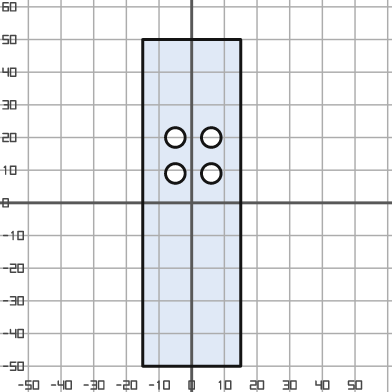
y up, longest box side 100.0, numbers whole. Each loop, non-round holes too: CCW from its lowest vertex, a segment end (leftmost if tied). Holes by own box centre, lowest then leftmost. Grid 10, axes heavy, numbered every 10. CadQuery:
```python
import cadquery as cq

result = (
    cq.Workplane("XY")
    .moveTo(-15.0, -50.0)
    .lineTo(15.0, -50.0)
    .lineTo(15.0, 50.0)
    .lineTo(-15.0, 50.0)
    .close()
    .moveTo(-5.0, 9.0)
    .circle(3.0)
    .moveTo(6.0, 9.0)
    .circle(3.0)
    .moveTo(-5.0, 20.0)
    .circle(3.0)
    .moveTo(6.0, 20.0)
    .circle(3.0)
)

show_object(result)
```